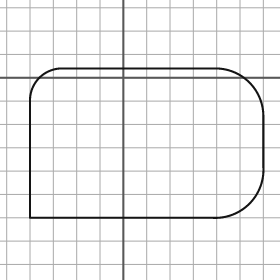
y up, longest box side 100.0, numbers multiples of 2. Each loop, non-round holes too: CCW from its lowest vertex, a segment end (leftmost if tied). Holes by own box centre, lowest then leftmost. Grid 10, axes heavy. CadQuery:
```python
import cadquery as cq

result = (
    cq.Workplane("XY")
    .moveTo(-40.0, -60.0)
    .lineTo(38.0, -60.0)
    .threePointArc((54.0, -54.0), (60.0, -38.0))
    .lineTo(60.0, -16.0)
    .threePointArc((54.0, -2.0), (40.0, 4.0))
    .lineTo(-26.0, 4.0)
    .threePointArc((-36.0, 0.0), (-40.0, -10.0))
    .close()
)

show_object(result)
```